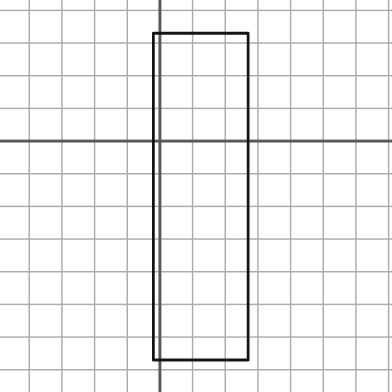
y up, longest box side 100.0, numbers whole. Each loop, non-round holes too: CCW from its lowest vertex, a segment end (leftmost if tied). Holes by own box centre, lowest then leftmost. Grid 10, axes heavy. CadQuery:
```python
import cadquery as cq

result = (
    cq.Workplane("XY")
    .moveTo(-2.0, -67.0)
    .lineTo(27.0, -67.0)
    .lineTo(27.0, 33.0)
    .lineTo(-2.0, 33.0)
    .close()
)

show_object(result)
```